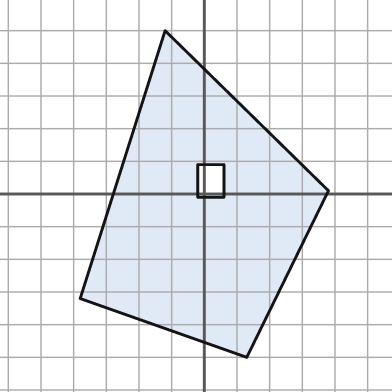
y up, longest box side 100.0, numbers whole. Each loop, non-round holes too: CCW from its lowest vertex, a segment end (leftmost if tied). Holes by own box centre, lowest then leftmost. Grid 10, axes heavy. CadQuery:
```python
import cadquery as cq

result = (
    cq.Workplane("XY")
    .moveTo(13.0, -50.0)
    .lineTo(38.0, 1.0)
    .lineTo(-12.0, 50.0)
    .lineTo(-38.0, -32.0)
    .close()
    .moveTo(-2.0, -1.0)
    .lineTo(6.0, -1.0)
    .lineTo(6.0, 9.0)
    .lineTo(-2.0, 9.0)
    .close()
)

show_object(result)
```